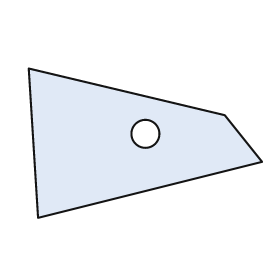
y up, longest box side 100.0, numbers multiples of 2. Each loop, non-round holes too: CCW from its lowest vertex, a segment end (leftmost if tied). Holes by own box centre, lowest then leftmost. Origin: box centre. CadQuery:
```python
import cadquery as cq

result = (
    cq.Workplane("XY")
    .moveTo(-46.0, -32.0)
    .lineTo(50.0, -8.0)
    .lineTo(34.0, 12.0)
    .lineTo(-50.0, 32.0)
    .close()
    .moveTo(0.0, 4.0)
    .circle(6.0)
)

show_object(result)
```